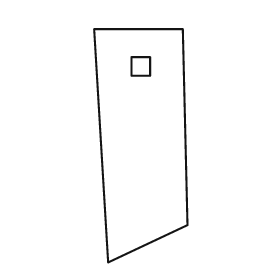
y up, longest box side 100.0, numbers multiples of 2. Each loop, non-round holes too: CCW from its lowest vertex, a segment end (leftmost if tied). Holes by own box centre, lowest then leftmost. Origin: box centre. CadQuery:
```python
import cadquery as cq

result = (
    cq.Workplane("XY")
    .moveTo(-14.0, -50.0)
    .lineTo(20.0, -34.0)
    .lineTo(18.0, 50.0)
    .lineTo(-20.0, 50.0)
    .close()
    .moveTo(-4.0, 30.0)
    .lineTo(4.0, 30.0)
    .lineTo(4.0, 38.0)
    .lineTo(-4.0, 38.0)
    .close()
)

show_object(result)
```